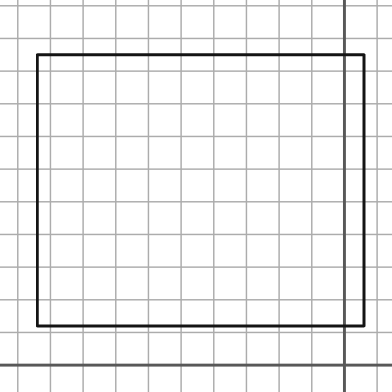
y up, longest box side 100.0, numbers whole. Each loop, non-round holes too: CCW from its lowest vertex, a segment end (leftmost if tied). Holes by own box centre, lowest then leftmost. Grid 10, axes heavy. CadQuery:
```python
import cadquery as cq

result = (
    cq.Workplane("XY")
    .moveTo(-94.0, 12.0)
    .lineTo(6.0, 12.0)
    .lineTo(6.0, 95.0)
    .lineTo(-94.0, 95.0)
    .close()
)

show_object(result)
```